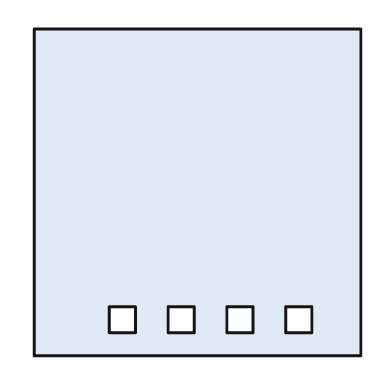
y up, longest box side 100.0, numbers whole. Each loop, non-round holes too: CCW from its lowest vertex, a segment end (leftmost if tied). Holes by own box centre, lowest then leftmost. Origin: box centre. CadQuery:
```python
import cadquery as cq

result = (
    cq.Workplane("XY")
    .moveTo(-50.0, -50.0)
    .lineTo(50.0, -50.0)
    .lineTo(50.0, 50.0)
    .lineTo(-50.0, 50.0)
    .close()
    .moveTo(-27.0, -43.0)
    .lineTo(-19.0, -43.0)
    .lineTo(-19.0, -35.0)
    .lineTo(-27.0, -35.0)
    .close()
    .moveTo(-9.0, -43.0)
    .lineTo(-1.0, -43.0)
    .lineTo(-1.0, -35.0)
    .lineTo(-9.0, -35.0)
    .close()
    .moveTo(9.0, -43.0)
    .lineTo(17.0, -43.0)
    .lineTo(17.0, -35.0)
    .lineTo(9.0, -35.0)
    .close()
    .moveTo(27.0, -43.0)
    .lineTo(35.0, -43.0)
    .lineTo(35.0, -35.0)
    .lineTo(27.0, -35.0)
    .close()
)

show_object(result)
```